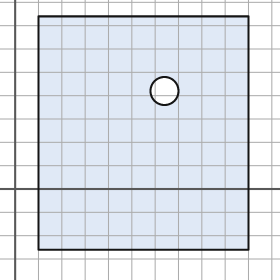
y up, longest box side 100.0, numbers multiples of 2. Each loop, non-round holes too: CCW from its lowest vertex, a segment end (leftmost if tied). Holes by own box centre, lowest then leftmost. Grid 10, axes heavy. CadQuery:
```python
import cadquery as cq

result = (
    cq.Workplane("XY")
    .moveTo(10.0, -26.0)
    .lineTo(100.0, -26.0)
    .lineTo(100.0, 74.0)
    .lineTo(10.0, 74.0)
    .close()
    .moveTo(64.0, 42.0)
    .circle(6.0)
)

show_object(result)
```